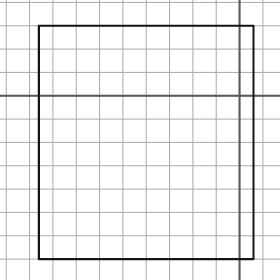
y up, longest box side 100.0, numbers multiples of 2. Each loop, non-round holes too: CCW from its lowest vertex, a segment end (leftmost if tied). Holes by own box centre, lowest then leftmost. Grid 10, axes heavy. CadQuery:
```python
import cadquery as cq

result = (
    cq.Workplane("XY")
    .moveTo(-86.0, -70.0)
    .lineTo(6.0, -70.0)
    .lineTo(6.0, 30.0)
    .lineTo(-86.0, 30.0)
    .close()
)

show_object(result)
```